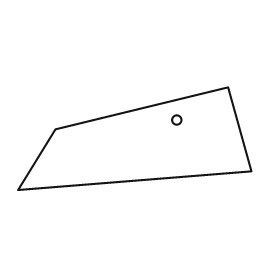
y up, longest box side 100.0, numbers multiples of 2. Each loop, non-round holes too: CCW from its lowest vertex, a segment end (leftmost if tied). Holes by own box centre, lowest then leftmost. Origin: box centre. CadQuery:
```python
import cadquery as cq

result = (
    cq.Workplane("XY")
    .moveTo(-50.0, -22.0)
    .lineTo(50.0, -14.0)
    .lineTo(40.0, 22.0)
    .lineTo(-34.0, 4.0)
    .close()
    .moveTo(18.0, 8.0)
    .circle(2.0)
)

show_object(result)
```